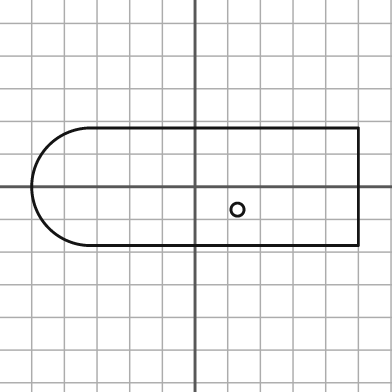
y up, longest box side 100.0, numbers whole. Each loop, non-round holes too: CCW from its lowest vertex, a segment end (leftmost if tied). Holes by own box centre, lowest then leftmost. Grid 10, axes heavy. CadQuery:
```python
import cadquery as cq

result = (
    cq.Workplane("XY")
    .moveTo(-32.0, -18.0)
    .lineTo(50.0, -18.0)
    .lineTo(50.0, 18.0)
    .lineTo(-32.0, 18.0)
    .threePointArc((-50.0, 0.0), (-32.0, -18.0))
    .close()
    .moveTo(13.0, -7.0)
    .circle(2.0)
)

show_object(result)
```